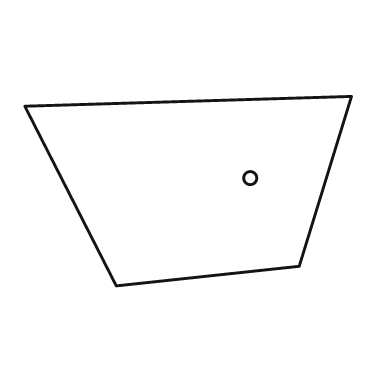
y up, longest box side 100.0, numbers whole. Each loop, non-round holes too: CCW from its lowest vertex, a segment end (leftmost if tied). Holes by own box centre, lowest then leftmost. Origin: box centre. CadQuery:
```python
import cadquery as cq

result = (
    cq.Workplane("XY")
    .moveTo(-22.0, -29.0)
    .lineTo(34.0, -23.0)
    .lineTo(50.0, 29.0)
    .lineTo(-50.0, 26.0)
    .close()
    .moveTo(19.0, 4.0)
    .circle(2.0)
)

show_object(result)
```